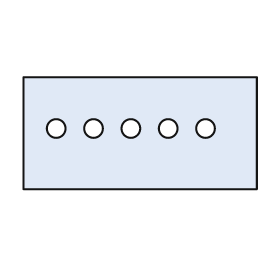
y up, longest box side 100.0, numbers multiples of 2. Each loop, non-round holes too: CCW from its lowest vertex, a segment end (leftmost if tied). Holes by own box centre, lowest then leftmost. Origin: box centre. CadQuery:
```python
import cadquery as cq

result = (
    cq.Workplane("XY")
    .moveTo(-50.0, -24.0)
    .lineTo(50.0, -24.0)
    .lineTo(50.0, 24.0)
    .lineTo(-50.0, 24.0)
    .close()
    .moveTo(-36.0, 2.0)
    .circle(4.0)
    .moveTo(-20.0, 2.0)
    .circle(4.0)
    .moveTo(-4.0, 2.0)
    .circle(4.0)
    .moveTo(12.0, 2.0)
    .circle(4.0)
    .moveTo(28.0, 2.0)
    .circle(4.0)
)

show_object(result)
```